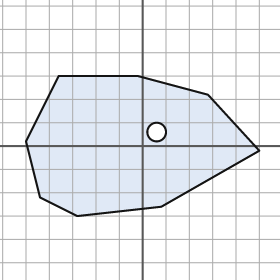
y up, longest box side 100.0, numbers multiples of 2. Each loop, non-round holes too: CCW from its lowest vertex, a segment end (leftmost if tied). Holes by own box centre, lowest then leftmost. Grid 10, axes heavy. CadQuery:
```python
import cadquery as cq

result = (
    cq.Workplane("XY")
    .moveTo(-28.0, -30.0)
    .lineTo(8.0, -26.0)
    .lineTo(50.0, -2.0)
    .lineTo(28.0, 22.0)
    .lineTo(-2.0, 30.0)
    .lineTo(-36.0, 30.0)
    .lineTo(-50.0, 2.0)
    .lineTo(-44.0, -22.0)
    .close()
    .moveTo(6.0, 6.0)
    .circle(4.0)
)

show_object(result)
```